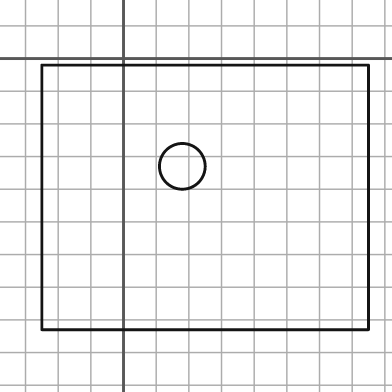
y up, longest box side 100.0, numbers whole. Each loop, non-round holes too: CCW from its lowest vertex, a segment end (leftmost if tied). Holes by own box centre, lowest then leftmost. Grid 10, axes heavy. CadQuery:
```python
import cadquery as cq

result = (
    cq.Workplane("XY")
    .moveTo(-25.0, -83.0)
    .lineTo(75.0, -83.0)
    .lineTo(75.0, -2.0)
    .lineTo(-25.0, -2.0)
    .close()
    .moveTo(18.0, -33.0)
    .circle(7.0)
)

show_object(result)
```